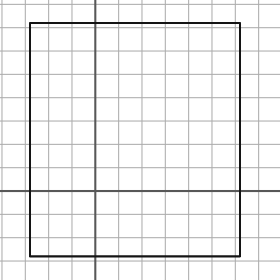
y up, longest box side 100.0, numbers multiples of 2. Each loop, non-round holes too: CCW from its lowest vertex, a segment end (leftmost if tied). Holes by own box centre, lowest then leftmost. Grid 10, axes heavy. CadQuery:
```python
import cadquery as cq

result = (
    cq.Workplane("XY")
    .moveTo(-28.0, -28.0)
    .lineTo(62.0, -28.0)
    .lineTo(62.0, 72.0)
    .lineTo(-28.0, 72.0)
    .close()
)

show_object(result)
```